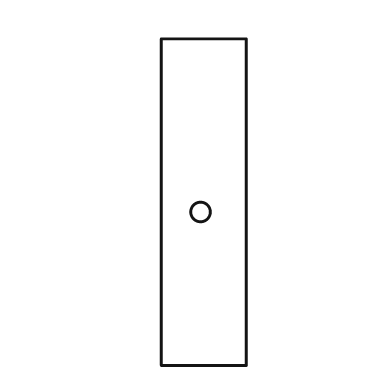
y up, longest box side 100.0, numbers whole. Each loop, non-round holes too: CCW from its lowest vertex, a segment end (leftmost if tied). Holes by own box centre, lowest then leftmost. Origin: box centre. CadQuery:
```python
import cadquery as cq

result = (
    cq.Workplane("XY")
    .moveTo(-13.0, -50.0)
    .lineTo(13.0, -50.0)
    .lineTo(13.0, 50.0)
    .lineTo(-13.0, 50.0)
    .close()
    .moveTo(-1.0, -3.0)
    .circle(3.0)
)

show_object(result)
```